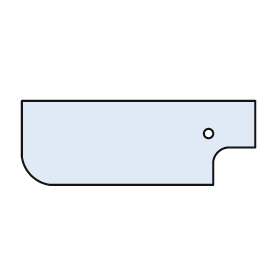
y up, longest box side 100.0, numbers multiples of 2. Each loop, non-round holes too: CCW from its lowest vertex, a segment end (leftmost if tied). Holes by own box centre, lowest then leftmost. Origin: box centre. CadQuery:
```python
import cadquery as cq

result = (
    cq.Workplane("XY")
    .moveTo(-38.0, -18.0)
    .lineTo(32.0, -18.0)
    .lineTo(32.0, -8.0)
    .threePointArc((34.0, -4.0), (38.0, -2.0))
    .lineTo(50.0, -2.0)
    .lineTo(50.0, 18.0)
    .lineTo(-50.0, 18.0)
    .lineTo(-50.0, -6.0)
    .threePointArc((-46.0, -14.0), (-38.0, -18.0))
    .close()
    .moveTo(30.0, 4.0)
    .circle(2.0)
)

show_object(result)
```